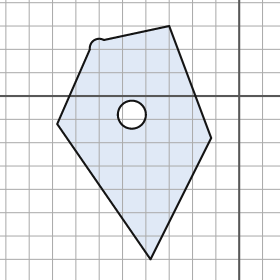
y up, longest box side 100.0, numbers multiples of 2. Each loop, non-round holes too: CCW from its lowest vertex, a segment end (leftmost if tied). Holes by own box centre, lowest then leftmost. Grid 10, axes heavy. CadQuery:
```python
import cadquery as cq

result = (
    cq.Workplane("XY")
    .moveTo(-38.0, -70.0)
    .lineTo(-12.0, -18.0)
    .lineTo(-30.0, 30.0)
    .lineTo(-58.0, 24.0)
    .threePointArc((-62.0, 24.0), (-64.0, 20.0))
    .lineTo(-78.0, -12.0)
    .close()
    .moveTo(-46.0, -8.0)
    .circle(6.0)
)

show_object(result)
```